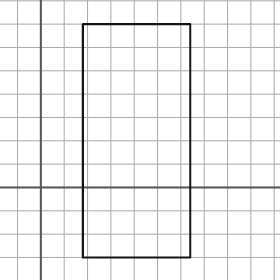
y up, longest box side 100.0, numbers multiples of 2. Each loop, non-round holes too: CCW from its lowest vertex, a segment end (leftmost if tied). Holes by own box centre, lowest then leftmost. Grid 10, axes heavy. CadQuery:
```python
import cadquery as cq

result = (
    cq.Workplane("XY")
    .moveTo(18.0, -30.0)
    .lineTo(64.0, -30.0)
    .lineTo(64.0, 70.0)
    .lineTo(18.0, 70.0)
    .close()
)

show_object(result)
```